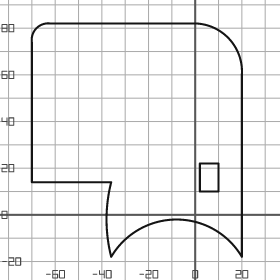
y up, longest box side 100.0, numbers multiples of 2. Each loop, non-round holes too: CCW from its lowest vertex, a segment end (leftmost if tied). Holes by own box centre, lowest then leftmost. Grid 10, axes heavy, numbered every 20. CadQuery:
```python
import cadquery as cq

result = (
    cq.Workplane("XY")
    .moveTo(-36.0, -18.0)
    .threePointArc((-8.0, -2.0), (20.0, -18.0))
    .lineTo(20.0, 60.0)
    .threePointArc((14.0, 76.0), (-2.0, 82.0))
    .lineTo(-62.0, 82.0)
    .threePointArc((-68.0, 80.0), (-70.0, 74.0))
    .lineTo(-70.0, 14.0)
    .lineTo(-36.0, 14.0)
    .threePointArc((-38.0, -2.0), (-36.0, -18.0))
    .close()
    .moveTo(2.0, 10.0)
    .lineTo(10.0, 10.0)
    .lineTo(10.0, 22.0)
    .lineTo(2.0, 22.0)
    .close()
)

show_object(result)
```